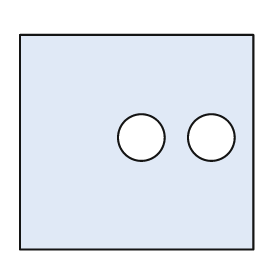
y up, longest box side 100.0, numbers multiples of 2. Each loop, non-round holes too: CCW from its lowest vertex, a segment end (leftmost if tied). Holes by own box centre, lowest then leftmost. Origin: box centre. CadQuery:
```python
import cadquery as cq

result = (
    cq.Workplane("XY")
    .moveTo(-50.0, -46.0)
    .lineTo(50.0, -46.0)
    .lineTo(50.0, 46.0)
    .lineTo(-50.0, 46.0)
    .close()
    .moveTo(2.0, 2.0)
    .circle(10.0)
    .moveTo(32.0, 2.0)
    .circle(10.0)
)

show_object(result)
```